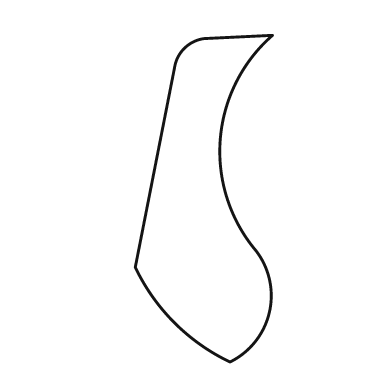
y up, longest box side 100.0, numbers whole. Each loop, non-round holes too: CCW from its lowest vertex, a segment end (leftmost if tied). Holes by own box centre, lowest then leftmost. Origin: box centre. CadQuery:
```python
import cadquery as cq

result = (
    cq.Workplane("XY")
    .moveTo(8.0, -50.0)
    .threePointArc((20.0, -35.0), (16.0, -16.0))
    .threePointArc((5.0, 18.0), (21.0, 50.0))
    .lineTo(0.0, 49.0)
    .threePointArc((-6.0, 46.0), (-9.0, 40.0))
    .lineTo(-21.0, -21.0)
    .threePointArc((-9.0, -38.0), (8.0, -50.0))
    .close()
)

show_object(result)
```